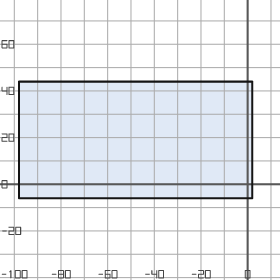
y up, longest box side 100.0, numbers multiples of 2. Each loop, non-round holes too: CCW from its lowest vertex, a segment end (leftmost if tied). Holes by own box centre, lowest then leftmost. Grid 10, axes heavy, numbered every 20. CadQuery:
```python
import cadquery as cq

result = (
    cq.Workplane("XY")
    .moveTo(-98.0, -6.0)
    .lineTo(2.0, -6.0)
    .lineTo(2.0, 44.0)
    .lineTo(-98.0, 44.0)
    .close()
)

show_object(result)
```